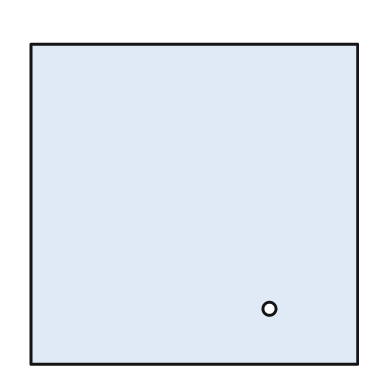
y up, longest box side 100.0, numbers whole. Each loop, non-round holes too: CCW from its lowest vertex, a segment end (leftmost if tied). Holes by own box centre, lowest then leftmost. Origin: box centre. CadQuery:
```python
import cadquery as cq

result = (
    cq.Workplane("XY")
    .moveTo(-50.0, -49.0)
    .lineTo(50.0, -49.0)
    .lineTo(50.0, 49.0)
    .lineTo(-50.0, 49.0)
    .close()
    .moveTo(23.0, -32.0)
    .circle(2.0)
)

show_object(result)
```